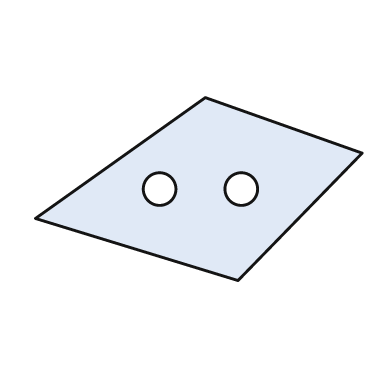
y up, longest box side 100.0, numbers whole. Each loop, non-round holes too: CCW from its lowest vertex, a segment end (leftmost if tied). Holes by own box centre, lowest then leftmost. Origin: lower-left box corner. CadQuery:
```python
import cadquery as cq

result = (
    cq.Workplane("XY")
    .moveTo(62.0, 0.0)
    .lineTo(100.0, 39.0)
    .lineTo(52.0, 56.0)
    .lineTo(0.0, 19.0)
    .close()
    .moveTo(38.0, 28.0)
    .circle(5.0)
    .moveTo(63.0, 28.0)
    .circle(5.0)
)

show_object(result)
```